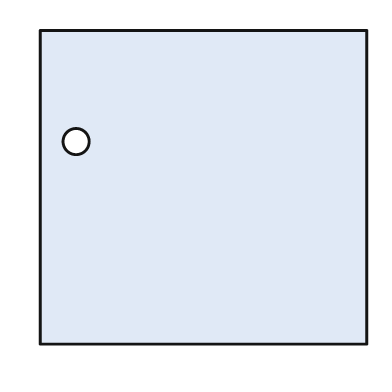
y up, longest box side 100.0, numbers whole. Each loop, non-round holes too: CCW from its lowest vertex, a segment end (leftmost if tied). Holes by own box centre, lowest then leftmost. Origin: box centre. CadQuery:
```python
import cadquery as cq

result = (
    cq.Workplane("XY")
    .moveTo(-50.0, -48.0)
    .lineTo(50.0, -48.0)
    .lineTo(50.0, 48.0)
    .lineTo(-50.0, 48.0)
    .close()
    .moveTo(-39.0, 14.0)
    .circle(4.0)
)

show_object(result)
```